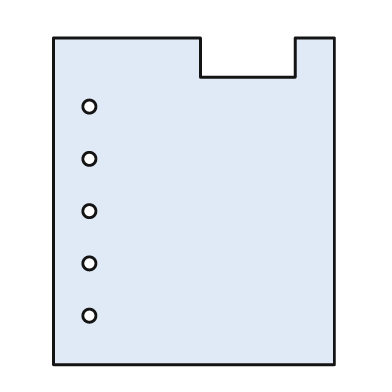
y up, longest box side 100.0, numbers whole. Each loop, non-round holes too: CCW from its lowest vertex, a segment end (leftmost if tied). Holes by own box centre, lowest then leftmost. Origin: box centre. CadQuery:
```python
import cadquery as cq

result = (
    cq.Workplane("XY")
    .moveTo(-43.0, -50.0)
    .lineTo(43.0, -50.0)
    .lineTo(43.0, 50.0)
    .lineTo(31.0, 50.0)
    .lineTo(31.0, 38.0)
    .lineTo(2.0, 38.0)
    .lineTo(2.0, 50.0)
    .lineTo(-43.0, 50.0)
    .close()
    .moveTo(-32.0, -35.0)
    .circle(2.0)
    .moveTo(-32.0, -19.0)
    .circle(2.0)
    .moveTo(-32.0, -3.0)
    .circle(2.0)
    .moveTo(-32.0, 13.0)
    .circle(2.0)
    .moveTo(-32.0, 29.0)
    .circle(2.0)
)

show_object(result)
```